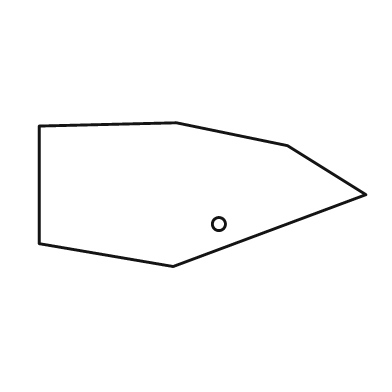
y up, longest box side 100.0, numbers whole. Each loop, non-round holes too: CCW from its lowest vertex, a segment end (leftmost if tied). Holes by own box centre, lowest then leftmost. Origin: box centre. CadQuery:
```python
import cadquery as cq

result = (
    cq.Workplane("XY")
    .moveTo(-9.0, -22.0)
    .lineTo(50.0, 0.0)
    .lineTo(26.0, 15.0)
    .lineTo(-8.0, 22.0)
    .lineTo(-50.0, 21.0)
    .lineTo(-50.0, -15.0)
    .close()
    .moveTo(5.0, -9.0)
    .circle(2.0)
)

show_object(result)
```